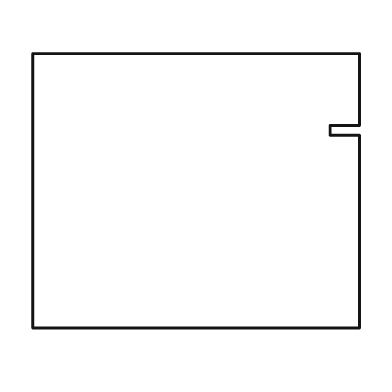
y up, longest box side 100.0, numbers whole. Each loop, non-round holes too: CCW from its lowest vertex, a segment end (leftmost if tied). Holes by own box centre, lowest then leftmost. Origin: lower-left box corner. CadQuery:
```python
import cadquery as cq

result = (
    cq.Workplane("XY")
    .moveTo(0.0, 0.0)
    .lineTo(100.0, 0.0)
    .lineTo(100.0, 59.0)
    .lineTo(91.0, 59.0)
    .lineTo(91.0, 62.0)
    .lineTo(100.0, 62.0)
    .lineTo(100.0, 84.0)
    .lineTo(0.0, 84.0)
    .close()
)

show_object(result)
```